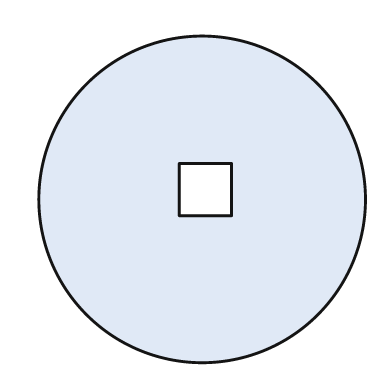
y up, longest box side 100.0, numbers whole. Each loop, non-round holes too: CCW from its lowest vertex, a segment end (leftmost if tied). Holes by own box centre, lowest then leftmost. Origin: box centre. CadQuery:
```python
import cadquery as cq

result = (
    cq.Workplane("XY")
    .moveTo(0.0, 0.0)
    .circle(50.0)
    .moveTo(-7.0, -5.0)
    .lineTo(9.0, -5.0)
    .lineTo(9.0, 11.0)
    .lineTo(-7.0, 11.0)
    .close()
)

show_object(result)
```